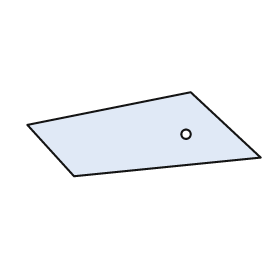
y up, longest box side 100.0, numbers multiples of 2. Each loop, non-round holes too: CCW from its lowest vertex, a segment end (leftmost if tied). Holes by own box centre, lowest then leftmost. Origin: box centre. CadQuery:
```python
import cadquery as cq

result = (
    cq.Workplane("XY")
    .moveTo(-30.0, -18.0)
    .lineTo(50.0, -10.0)
    .lineTo(20.0, 18.0)
    .lineTo(-50.0, 4.0)
    .close()
    .moveTo(18.0, 0.0)
    .circle(2.0)
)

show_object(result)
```